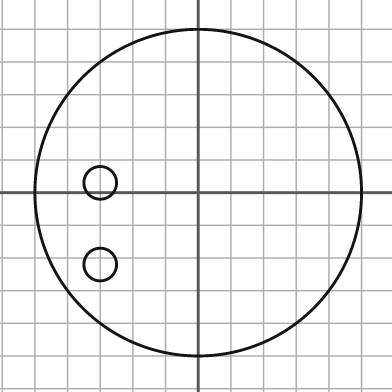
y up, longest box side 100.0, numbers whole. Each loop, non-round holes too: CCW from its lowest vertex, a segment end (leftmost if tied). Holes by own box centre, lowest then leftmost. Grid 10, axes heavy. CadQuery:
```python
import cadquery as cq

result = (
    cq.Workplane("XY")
    .moveTo(0.0, 0.0)
    .circle(50.0)
    .moveTo(-30.0, -22.0)
    .circle(5.0)
    .moveTo(-30.0, 3.0)
    .circle(5.0)
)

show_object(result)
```